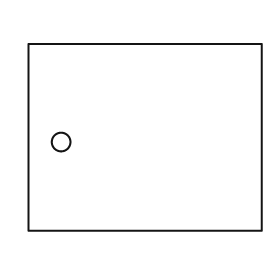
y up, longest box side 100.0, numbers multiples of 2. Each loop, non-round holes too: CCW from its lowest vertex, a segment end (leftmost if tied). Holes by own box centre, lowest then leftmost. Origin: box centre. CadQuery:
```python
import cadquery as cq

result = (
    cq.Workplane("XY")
    .moveTo(-50.0, -40.0)
    .lineTo(50.0, -40.0)
    .lineTo(50.0, 40.0)
    .lineTo(-50.0, 40.0)
    .close()
    .moveTo(-36.0, -2.0)
    .circle(4.0)
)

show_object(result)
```